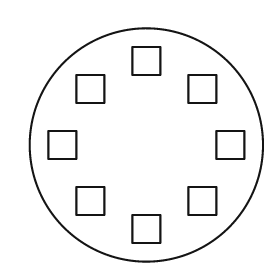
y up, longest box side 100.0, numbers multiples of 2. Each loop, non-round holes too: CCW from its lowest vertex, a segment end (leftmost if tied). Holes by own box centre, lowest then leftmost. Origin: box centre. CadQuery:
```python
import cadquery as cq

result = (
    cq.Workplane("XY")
    .moveTo(0.0, 0.0)
    .circle(50.0)
    .moveTo(-6.0, -42.0)
    .lineTo(6.0, -42.0)
    .lineTo(6.0, -30.0)
    .lineTo(-6.0, -30.0)
    .close()
    .moveTo(-30.0, -30.0)
    .lineTo(-18.0, -30.0)
    .lineTo(-18.0, -18.0)
    .lineTo(-30.0, -18.0)
    .close()
    .moveTo(18.0, -30.0)
    .lineTo(30.0, -30.0)
    .lineTo(30.0, -18.0)
    .lineTo(18.0, -18.0)
    .close()
    .moveTo(-42.0, -6.0)
    .lineTo(-30.0, -6.0)
    .lineTo(-30.0, 6.0)
    .lineTo(-42.0, 6.0)
    .close()
    .moveTo(30.0, -6.0)
    .lineTo(42.0, -6.0)
    .lineTo(42.0, 6.0)
    .lineTo(30.0, 6.0)
    .close()
    .moveTo(-30.0, 18.0)
    .lineTo(-18.0, 18.0)
    .lineTo(-18.0, 30.0)
    .lineTo(-30.0, 30.0)
    .close()
    .moveTo(18.0, 18.0)
    .lineTo(30.0, 18.0)
    .lineTo(30.0, 30.0)
    .lineTo(18.0, 30.0)
    .close()
    .moveTo(-6.0, 30.0)
    .lineTo(6.0, 30.0)
    .lineTo(6.0, 42.0)
    .lineTo(-6.0, 42.0)
    .close()
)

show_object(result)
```